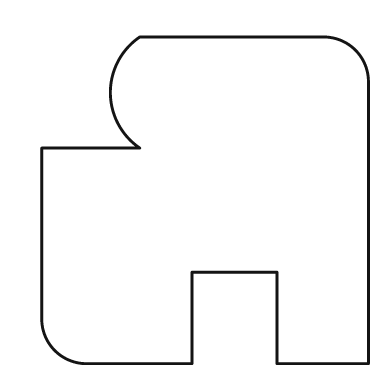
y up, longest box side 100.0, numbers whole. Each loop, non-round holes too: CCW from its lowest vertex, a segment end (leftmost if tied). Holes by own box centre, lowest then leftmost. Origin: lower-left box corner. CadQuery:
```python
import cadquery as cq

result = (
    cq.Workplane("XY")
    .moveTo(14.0, 0.0)
    .lineTo(46.0, 0.0)
    .lineTo(46.0, 28.0)
    .lineTo(72.0, 28.0)
    .lineTo(72.0, 0.0)
    .lineTo(100.0, 0.0)
    .lineTo(100.0, 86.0)
    .threePointArc((96.0, 96.0), (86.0, 100.0))
    .lineTo(30.0, 100.0)
    .threePointArc((21.0, 83.0), (30.0, 66.0))
    .lineTo(0.0, 66.0)
    .lineTo(0.0, 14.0)
    .threePointArc((4.0, 4.0), (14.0, 0.0))
    .close()
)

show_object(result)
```